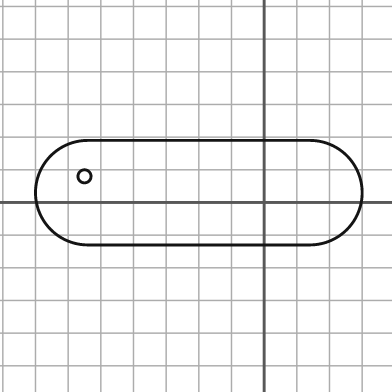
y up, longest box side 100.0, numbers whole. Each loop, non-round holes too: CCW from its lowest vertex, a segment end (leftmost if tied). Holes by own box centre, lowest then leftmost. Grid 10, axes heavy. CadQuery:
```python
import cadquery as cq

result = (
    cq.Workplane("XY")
    .moveTo(-54.0, -13.0)
    .lineTo(14.0, -13.0)
    .threePointArc((30.0, 3.0), (14.0, 19.0))
    .lineTo(-54.0, 19.0)
    .threePointArc((-70.0, 3.0), (-54.0, -13.0))
    .close()
    .moveTo(-55.0, 8.0)
    .circle(2.0)
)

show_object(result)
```